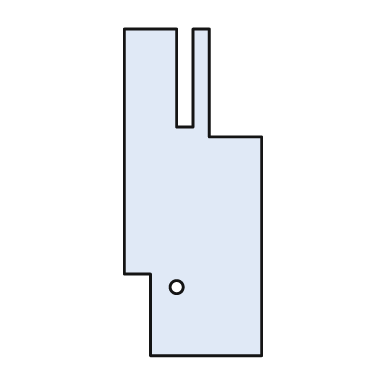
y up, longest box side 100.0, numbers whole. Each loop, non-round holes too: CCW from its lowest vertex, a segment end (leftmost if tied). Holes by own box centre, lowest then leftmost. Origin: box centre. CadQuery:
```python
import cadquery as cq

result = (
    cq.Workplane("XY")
    .moveTo(-13.0, -50.0)
    .lineTo(21.0, -50.0)
    .lineTo(21.0, 17.0)
    .lineTo(5.0, 17.0)
    .lineTo(5.0, 50.0)
    .lineTo(0.0, 50.0)
    .lineTo(0.0, 20.0)
    .lineTo(-5.0, 20.0)
    .lineTo(-5.0, 50.0)
    .lineTo(-21.0, 50.0)
    .lineTo(-21.0, -25.0)
    .lineTo(-13.0, -25.0)
    .close()
    .moveTo(-5.0, -29.0)
    .circle(2.0)
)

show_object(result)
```